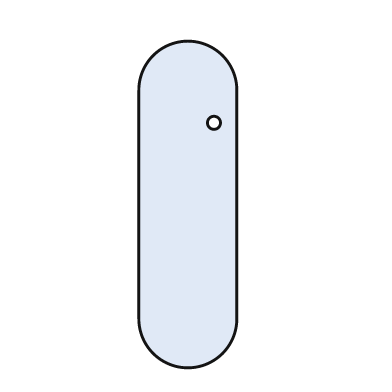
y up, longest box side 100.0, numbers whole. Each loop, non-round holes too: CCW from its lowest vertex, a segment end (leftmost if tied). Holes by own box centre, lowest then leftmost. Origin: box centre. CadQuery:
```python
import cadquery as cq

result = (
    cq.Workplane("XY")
    .moveTo(-15.0, -35.0)
    .threePointArc((0.0, -50.0), (15.0, -35.0))
    .lineTo(15.0, 35.0)
    .threePointArc((0.0, 50.0), (-15.0, 35.0))
    .close()
    .moveTo(8.0, 25.0)
    .circle(2.0)
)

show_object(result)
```